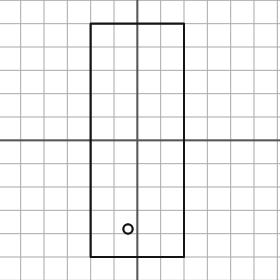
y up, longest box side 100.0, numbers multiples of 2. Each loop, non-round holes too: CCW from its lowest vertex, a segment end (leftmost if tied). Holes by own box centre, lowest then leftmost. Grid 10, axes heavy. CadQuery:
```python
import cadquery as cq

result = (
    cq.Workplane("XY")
    .moveTo(-20.0, -50.0)
    .lineTo(20.0, -50.0)
    .lineTo(20.0, 50.0)
    .lineTo(-20.0, 50.0)
    .close()
    .moveTo(-4.0, -38.0)
    .circle(2.0)
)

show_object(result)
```